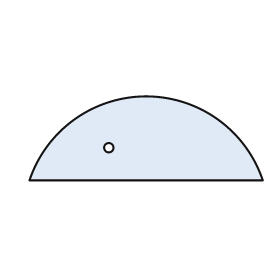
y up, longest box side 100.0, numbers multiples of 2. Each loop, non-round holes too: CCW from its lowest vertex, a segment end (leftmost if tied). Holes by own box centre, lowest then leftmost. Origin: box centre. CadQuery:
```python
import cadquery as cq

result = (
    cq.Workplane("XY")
    .moveTo(-50.0, -18.0)
    .lineTo(50.0, -18.0)
    .threePointArc((0.0, 18.0), (-50.0, -18.0))
    .close()
    .moveTo(-16.0, -4.0)
    .circle(2.0)
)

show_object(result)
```